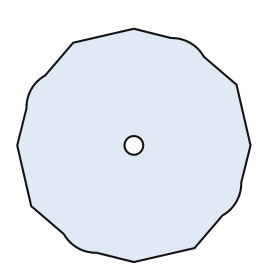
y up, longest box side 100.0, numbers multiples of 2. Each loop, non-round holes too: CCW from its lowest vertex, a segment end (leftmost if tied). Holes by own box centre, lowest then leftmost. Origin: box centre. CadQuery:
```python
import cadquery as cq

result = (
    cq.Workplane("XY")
    .moveTo(0.0, -50.0)
    .lineTo(26.0, -44.0)
    .lineTo(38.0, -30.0)
    .threePointArc((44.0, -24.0), (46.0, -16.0))
    .lineTo(50.0, 0.0)
    .lineTo(44.0, 26.0)
    .lineTo(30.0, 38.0)
    .threePointArc((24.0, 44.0), (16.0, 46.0))
    .lineTo(0.0, 50.0)
    .lineTo(-26.0, 44.0)
    .lineTo(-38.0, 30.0)
    .threePointArc((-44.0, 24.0), (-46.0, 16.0))
    .lineTo(-50.0, 0.0)
    .lineTo(-44.0, -26.0)
    .lineTo(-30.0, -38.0)
    .threePointArc((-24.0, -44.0), (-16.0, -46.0))
    .close()
    .moveTo(0.0, 0.0)
    .circle(4.0)
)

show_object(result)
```